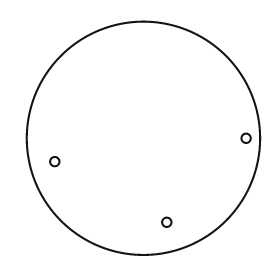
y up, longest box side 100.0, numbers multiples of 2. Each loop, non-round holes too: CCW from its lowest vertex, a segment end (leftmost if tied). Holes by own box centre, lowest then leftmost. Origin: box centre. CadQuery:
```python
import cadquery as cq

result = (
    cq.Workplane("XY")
    .moveTo(0.0, 0.0)
    .circle(50.0)
    .moveTo(10.0, -36.0)
    .circle(2.0)
    .moveTo(-38.0, -10.0)
    .circle(2.0)
    .moveTo(44.0, 0.0)
    .circle(2.0)
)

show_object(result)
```